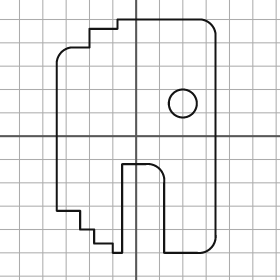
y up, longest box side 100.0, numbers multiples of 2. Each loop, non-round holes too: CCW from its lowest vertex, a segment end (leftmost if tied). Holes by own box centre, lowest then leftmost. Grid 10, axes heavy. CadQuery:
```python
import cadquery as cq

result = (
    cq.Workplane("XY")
    .moveTo(-10.0, -50.0)
    .lineTo(-6.0, -50.0)
    .lineTo(-6.0, -12.0)
    .lineTo(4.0, -12.0)
    .threePointArc((10.0, -14.0), (12.0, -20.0))
    .lineTo(12.0, -50.0)
    .lineTo(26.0, -50.0)
    .threePointArc((32.0, -48.0), (34.0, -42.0))
    .lineTo(34.0, 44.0)
    .threePointArc((32.0, 48.0), (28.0, 50.0))
    .lineTo(-8.0, 50.0)
    .lineTo(-8.0, 46.0)
    .lineTo(-20.0, 46.0)
    .lineTo(-20.0, 38.0)
    .lineTo(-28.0, 38.0)
    .threePointArc((-32.0, 36.0), (-34.0, 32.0))
    .lineTo(-34.0, -32.0)
    .lineTo(-24.0, -32.0)
    .lineTo(-24.0, -40.0)
    .lineTo(-18.0, -40.0)
    .lineTo(-18.0, -46.0)
    .lineTo(-10.0, -46.0)
    .close()
    .moveTo(20.0, 14.0)
    .circle(6.0)
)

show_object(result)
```